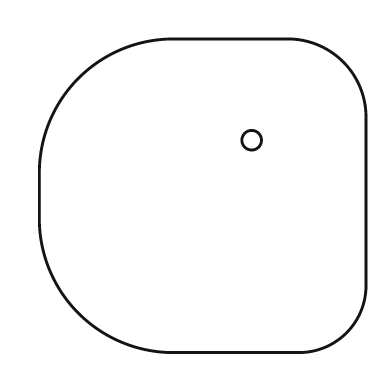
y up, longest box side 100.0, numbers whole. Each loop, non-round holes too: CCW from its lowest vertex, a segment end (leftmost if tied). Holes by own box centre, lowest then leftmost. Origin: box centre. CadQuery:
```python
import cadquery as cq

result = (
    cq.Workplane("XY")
    .moveTo(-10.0, -48.0)
    .lineTo(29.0, -48.0)
    .threePointArc((44.0, -42.0), (50.0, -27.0))
    .lineTo(50.0, 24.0)
    .threePointArc((43.0, 41.0), (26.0, 48.0))
    .lineTo(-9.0, 48.0)
    .threePointArc((-38.0, 36.0), (-50.0, 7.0))
    .lineTo(-50.0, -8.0)
    .threePointArc((-38.0, -36.0), (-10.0, -48.0))
    .close()
    .moveTo(15.0, 17.0)
    .circle(3.0)
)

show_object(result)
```